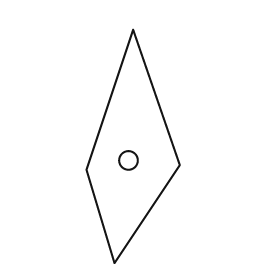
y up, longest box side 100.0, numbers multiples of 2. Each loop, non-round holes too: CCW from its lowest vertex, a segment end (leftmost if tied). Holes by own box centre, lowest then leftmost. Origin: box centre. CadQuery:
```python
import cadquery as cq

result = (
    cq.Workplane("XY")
    .moveTo(-8.0, -50.0)
    .lineTo(20.0, -8.0)
    .lineTo(0.0, 50.0)
    .lineTo(-20.0, -10.0)
    .close()
    .moveTo(-2.0, -6.0)
    .circle(4.0)
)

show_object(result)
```